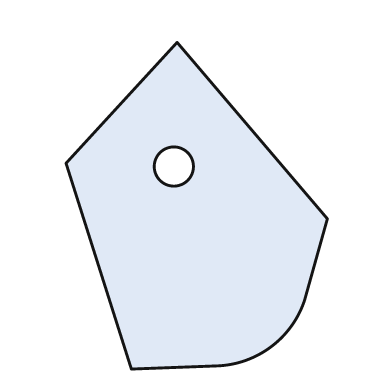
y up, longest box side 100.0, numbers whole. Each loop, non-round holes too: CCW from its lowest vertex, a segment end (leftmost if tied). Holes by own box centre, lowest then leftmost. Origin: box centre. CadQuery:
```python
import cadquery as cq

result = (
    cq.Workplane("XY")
    .moveTo(-20.0, -50.0)
    .lineTo(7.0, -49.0)
    .threePointArc((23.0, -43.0), (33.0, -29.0))
    .lineTo(40.0, -4.0)
    .lineTo(-6.0, 50.0)
    .lineTo(-40.0, 13.0)
    .close()
    .moveTo(-7.0, 12.0)
    .circle(6.0)
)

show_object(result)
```